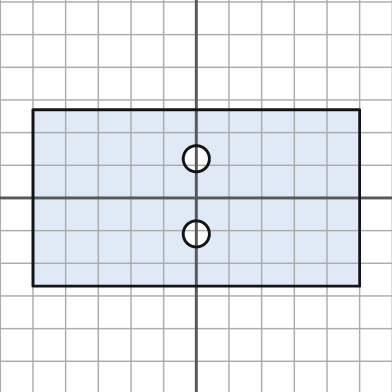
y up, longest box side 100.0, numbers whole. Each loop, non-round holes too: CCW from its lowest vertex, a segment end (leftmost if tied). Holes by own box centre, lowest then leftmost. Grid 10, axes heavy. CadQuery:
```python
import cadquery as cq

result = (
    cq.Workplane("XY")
    .moveTo(-50.0, -27.0)
    .lineTo(50.0, -27.0)
    .lineTo(50.0, 27.0)
    .lineTo(-50.0, 27.0)
    .close()
    .moveTo(0.0, -11.0)
    .circle(4.0)
    .moveTo(0.0, 12.0)
    .circle(4.0)
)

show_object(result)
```